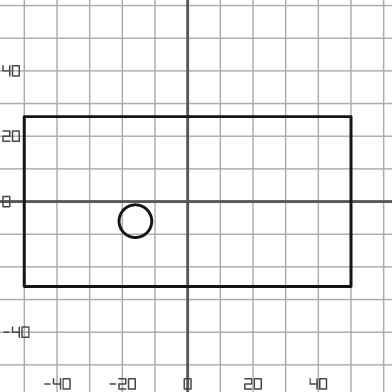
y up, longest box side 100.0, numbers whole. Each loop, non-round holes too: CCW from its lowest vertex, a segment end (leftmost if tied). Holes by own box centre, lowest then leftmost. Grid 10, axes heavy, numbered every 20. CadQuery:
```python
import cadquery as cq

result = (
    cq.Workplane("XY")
    .moveTo(-50.0, -26.0)
    .lineTo(50.0, -26.0)
    .lineTo(50.0, 26.0)
    .lineTo(-50.0, 26.0)
    .close()
    .moveTo(-16.0, -6.0)
    .circle(5.0)
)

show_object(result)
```